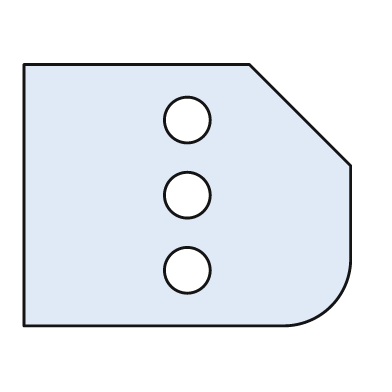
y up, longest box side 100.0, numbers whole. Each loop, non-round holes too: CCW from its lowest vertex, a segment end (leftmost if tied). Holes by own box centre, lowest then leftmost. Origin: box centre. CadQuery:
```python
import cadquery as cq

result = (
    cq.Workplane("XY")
    .moveTo(-50.0, -40.0)
    .lineTo(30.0, -40.0)
    .threePointArc((44.0, -34.0), (50.0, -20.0))
    .lineTo(50.0, 9.0)
    .lineTo(19.0, 40.0)
    .lineTo(-50.0, 40.0)
    .close()
    .moveTo(0.0, -23.0)
    .circle(7.0)
    .moveTo(0.0, 0.0)
    .circle(7.0)
    .moveTo(0.0, 23.0)
    .circle(7.0)
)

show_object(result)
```